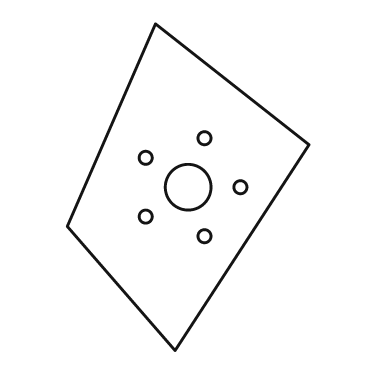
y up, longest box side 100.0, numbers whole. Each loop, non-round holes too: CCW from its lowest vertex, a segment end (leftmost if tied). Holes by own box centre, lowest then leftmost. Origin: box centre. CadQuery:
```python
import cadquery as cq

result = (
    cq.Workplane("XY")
    .moveTo(-4.0, -50.0)
    .lineTo(37.0, 13.0)
    .lineTo(-10.0, 50.0)
    .lineTo(-37.0, -12.0)
    .close()
    .moveTo(5.0, -15.0)
    .circle(2.0)
    .moveTo(-13.0, -9.0)
    .circle(2.0)
    .moveTo(0.0, 0.0)
    .circle(7.0)
    .moveTo(16.0, 0.0)
    .circle(2.0)
    .moveTo(-13.0, 9.0)
    .circle(2.0)
    .moveTo(5.0, 15.0)
    .circle(2.0)
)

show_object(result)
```